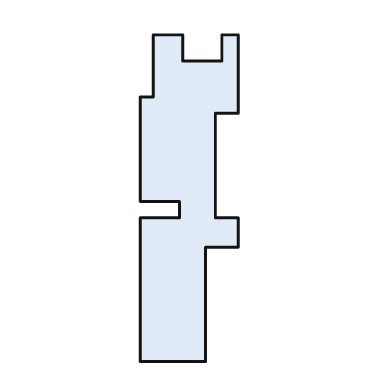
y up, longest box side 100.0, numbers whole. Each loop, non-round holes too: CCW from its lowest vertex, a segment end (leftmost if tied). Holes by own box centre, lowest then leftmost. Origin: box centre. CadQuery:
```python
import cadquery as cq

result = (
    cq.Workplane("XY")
    .moveTo(-15.0, -50.0)
    .lineTo(5.0, -50.0)
    .lineTo(5.0, -15.0)
    .lineTo(15.0, -15.0)
    .lineTo(15.0, -6.0)
    .lineTo(8.0, -6.0)
    .lineTo(8.0, 26.0)
    .lineTo(15.0, 26.0)
    .lineTo(15.0, 50.0)
    .lineTo(10.0, 50.0)
    .lineTo(10.0, 42.0)
    .lineTo(-2.0, 42.0)
    .lineTo(-2.0, 50.0)
    .lineTo(-11.0, 50.0)
    .lineTo(-11.0, 31.0)
    .lineTo(-15.0, 31.0)
    .lineTo(-15.0, -1.0)
    .lineTo(-3.0, -1.0)
    .lineTo(-3.0, -6.0)
    .lineTo(-15.0, -6.0)
    .close()
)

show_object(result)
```